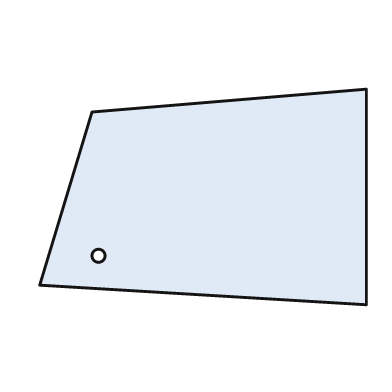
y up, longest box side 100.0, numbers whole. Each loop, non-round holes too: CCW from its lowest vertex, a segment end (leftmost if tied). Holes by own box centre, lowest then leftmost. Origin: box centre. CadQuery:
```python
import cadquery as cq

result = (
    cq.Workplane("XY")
    .moveTo(50.0, -33.0)
    .lineTo(50.0, 33.0)
    .lineTo(-34.0, 26.0)
    .lineTo(-50.0, -27.0)
    .close()
    .moveTo(-32.0, -18.0)
    .circle(2.0)
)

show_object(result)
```